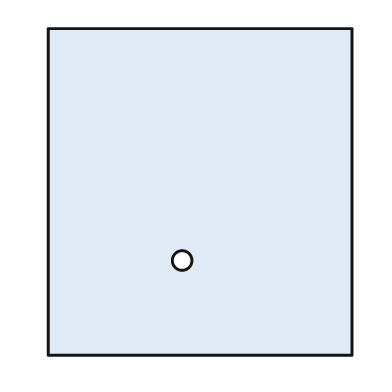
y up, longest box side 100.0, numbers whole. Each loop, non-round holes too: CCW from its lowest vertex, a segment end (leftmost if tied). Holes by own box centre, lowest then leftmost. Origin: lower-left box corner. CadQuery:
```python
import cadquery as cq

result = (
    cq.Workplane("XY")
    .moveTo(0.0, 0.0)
    .lineTo(93.0, 0.0)
    .lineTo(93.0, 100.0)
    .lineTo(0.0, 100.0)
    .close()
    .moveTo(41.0, 29.0)
    .circle(3.0)
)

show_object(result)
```